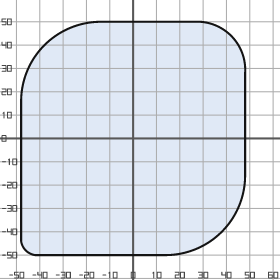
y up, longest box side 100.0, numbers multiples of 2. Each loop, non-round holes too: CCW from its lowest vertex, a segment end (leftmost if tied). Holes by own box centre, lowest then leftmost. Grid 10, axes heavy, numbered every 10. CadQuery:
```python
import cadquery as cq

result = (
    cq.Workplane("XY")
    .moveTo(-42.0, -50.0)
    .lineTo(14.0, -50.0)
    .threePointArc((38.0, -40.0), (48.0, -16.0))
    .lineTo(48.0, 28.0)
    .threePointArc((42.0, 44.0), (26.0, 50.0))
    .lineTo(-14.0, 50.0)
    .threePointArc((-38.0, 40.0), (-48.0, 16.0))
    .lineTo(-48.0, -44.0)
    .threePointArc((-46.0, -48.0), (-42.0, -50.0))
    .close()
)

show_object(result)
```